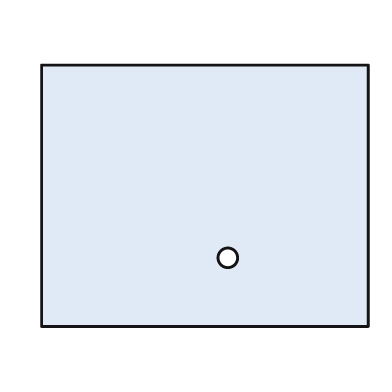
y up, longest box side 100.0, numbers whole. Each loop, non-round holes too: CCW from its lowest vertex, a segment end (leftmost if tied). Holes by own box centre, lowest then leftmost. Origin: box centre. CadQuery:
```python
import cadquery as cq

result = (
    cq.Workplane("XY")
    .moveTo(-50.0, -40.0)
    .lineTo(50.0, -40.0)
    .lineTo(50.0, 40.0)
    .lineTo(-50.0, 40.0)
    .close()
    .moveTo(7.0, -19.0)
    .circle(3.0)
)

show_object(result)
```